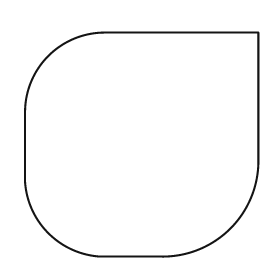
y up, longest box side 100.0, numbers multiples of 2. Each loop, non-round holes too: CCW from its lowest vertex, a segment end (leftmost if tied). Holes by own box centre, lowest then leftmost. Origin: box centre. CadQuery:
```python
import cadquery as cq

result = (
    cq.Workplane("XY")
    .moveTo(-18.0, -48.0)
    .lineTo(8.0, -48.0)
    .threePointArc((38.0, -36.0), (50.0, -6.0))
    .lineTo(50.0, 48.0)
    .lineTo(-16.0, 48.0)
    .threePointArc((-40.0, 38.0), (-50.0, 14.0))
    .lineTo(-50.0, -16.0)
    .threePointArc((-40.0, -38.0), (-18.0, -48.0))
    .close()
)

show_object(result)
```